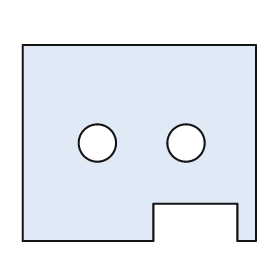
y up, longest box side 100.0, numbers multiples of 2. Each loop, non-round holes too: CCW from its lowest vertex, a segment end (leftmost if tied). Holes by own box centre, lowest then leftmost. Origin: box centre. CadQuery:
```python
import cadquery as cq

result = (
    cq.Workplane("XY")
    .moveTo(-50.0, -42.0)
    .lineTo(6.0, -42.0)
    .lineTo(6.0, -26.0)
    .lineTo(42.0, -26.0)
    .lineTo(42.0, -42.0)
    .lineTo(50.0, -42.0)
    .lineTo(50.0, 42.0)
    .lineTo(-50.0, 42.0)
    .close()
    .moveTo(-18.0, 0.0)
    .circle(8.0)
    .moveTo(20.0, 0.0)
    .circle(8.0)
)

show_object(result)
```